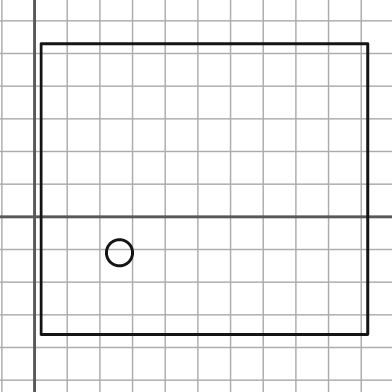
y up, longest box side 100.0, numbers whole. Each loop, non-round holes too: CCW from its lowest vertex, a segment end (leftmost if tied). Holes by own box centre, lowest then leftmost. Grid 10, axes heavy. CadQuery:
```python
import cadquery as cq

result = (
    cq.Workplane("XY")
    .moveTo(2.0, -36.0)
    .lineTo(102.0, -36.0)
    .lineTo(102.0, 53.0)
    .lineTo(2.0, 53.0)
    .close()
    .moveTo(26.0, -11.0)
    .circle(4.0)
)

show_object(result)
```